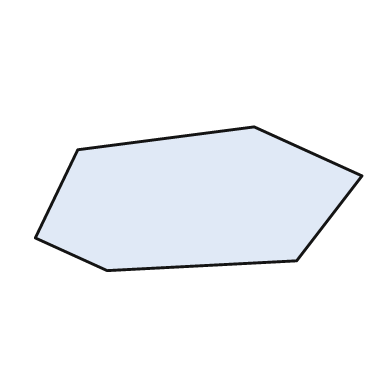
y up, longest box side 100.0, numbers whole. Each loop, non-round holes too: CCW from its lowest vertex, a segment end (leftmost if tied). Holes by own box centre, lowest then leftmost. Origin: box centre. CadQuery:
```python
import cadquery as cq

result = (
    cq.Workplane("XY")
    .moveTo(-28.0, -22.0)
    .lineTo(30.0, -19.0)
    .lineTo(50.0, 7.0)
    .lineTo(17.0, 22.0)
    .lineTo(-37.0, 15.0)
    .lineTo(-50.0, -12.0)
    .close()
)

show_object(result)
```